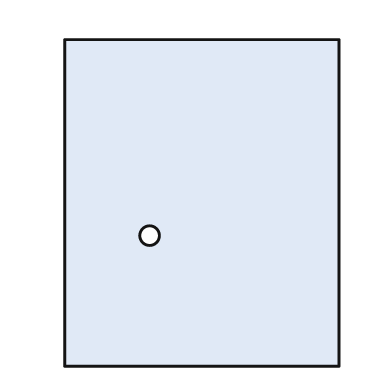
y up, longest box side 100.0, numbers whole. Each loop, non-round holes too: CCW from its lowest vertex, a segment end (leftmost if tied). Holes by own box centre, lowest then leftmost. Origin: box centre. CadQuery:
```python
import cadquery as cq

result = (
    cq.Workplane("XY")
    .moveTo(-42.0, -50.0)
    .lineTo(42.0, -50.0)
    .lineTo(42.0, 50.0)
    .lineTo(-42.0, 50.0)
    .close()
    .moveTo(-16.0, -10.0)
    .circle(3.0)
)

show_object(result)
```